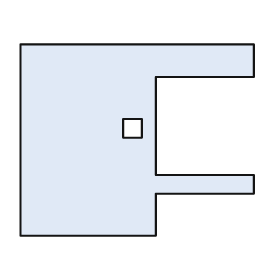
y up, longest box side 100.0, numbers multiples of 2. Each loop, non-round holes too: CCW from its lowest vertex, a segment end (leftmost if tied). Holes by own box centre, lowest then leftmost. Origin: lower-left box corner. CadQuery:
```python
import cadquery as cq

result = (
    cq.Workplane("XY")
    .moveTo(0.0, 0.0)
    .lineTo(58.0, 0.0)
    .lineTo(58.0, 18.0)
    .lineTo(100.0, 18.0)
    .lineTo(100.0, 26.0)
    .lineTo(58.0, 26.0)
    .lineTo(58.0, 68.0)
    .lineTo(100.0, 68.0)
    .lineTo(100.0, 82.0)
    .lineTo(0.0, 82.0)
    .close()
    .moveTo(44.0, 42.0)
    .lineTo(52.0, 42.0)
    .lineTo(52.0, 50.0)
    .lineTo(44.0, 50.0)
    .close()
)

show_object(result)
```